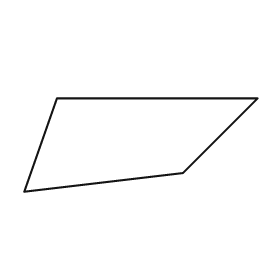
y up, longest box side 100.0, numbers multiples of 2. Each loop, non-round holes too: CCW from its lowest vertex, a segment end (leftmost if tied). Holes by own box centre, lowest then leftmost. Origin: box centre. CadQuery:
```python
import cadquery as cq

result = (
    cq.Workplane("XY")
    .moveTo(-50.0, -20.0)
    .lineTo(18.0, -12.0)
    .lineTo(50.0, 20.0)
    .lineTo(-36.0, 20.0)
    .close()
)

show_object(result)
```